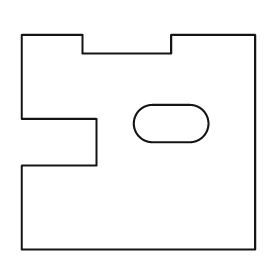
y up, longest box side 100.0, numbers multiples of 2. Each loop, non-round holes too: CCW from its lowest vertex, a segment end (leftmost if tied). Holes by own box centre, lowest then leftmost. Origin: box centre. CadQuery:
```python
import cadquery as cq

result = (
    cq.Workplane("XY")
    .moveTo(-50.0, -46.0)
    .lineTo(50.0, -46.0)
    .lineTo(50.0, 46.0)
    .lineTo(14.0, 46.0)
    .lineTo(14.0, 38.0)
    .lineTo(-24.0, 38.0)
    .lineTo(-24.0, 46.0)
    .lineTo(-50.0, 46.0)
    .lineTo(-50.0, 10.0)
    .lineTo(-18.0, 10.0)
    .lineTo(-18.0, -10.0)
    .lineTo(-50.0, -10.0)
    .close()
    .moveTo(6.0, 0.0)
    .lineTo(22.0, 0.0)
    .threePointArc((30.0, 8.0), (22.0, 16.0))
    .lineTo(6.0, 16.0)
    .threePointArc((-2.0, 8.0), (6.0, 0.0))
    .close()
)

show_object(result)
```